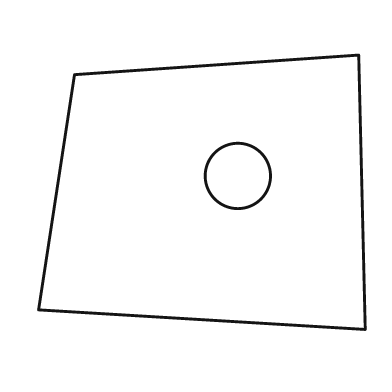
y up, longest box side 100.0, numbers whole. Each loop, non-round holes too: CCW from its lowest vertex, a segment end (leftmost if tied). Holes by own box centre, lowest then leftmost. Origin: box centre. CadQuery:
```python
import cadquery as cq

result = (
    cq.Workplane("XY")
    .moveTo(50.0, -42.0)
    .lineTo(48.0, 42.0)
    .lineTo(-39.0, 36.0)
    .lineTo(-50.0, -36.0)
    .close()
    .moveTo(11.0, 5.0)
    .circle(10.0)
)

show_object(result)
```